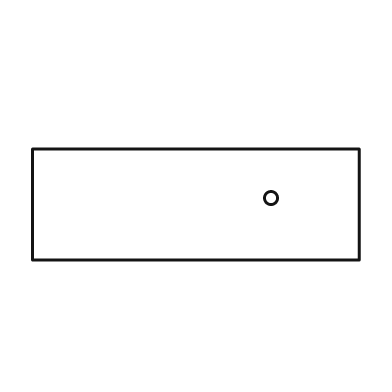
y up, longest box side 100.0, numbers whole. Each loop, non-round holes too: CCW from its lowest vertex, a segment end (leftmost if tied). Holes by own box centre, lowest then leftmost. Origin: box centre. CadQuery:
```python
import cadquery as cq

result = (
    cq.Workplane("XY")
    .moveTo(-50.0, -17.0)
    .lineTo(50.0, -17.0)
    .lineTo(50.0, 17.0)
    .lineTo(-50.0, 17.0)
    .close()
    .moveTo(23.0, 2.0)
    .circle(2.0)
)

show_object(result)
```